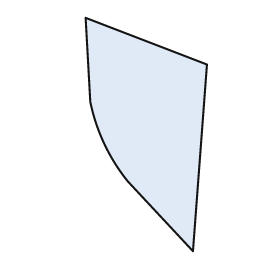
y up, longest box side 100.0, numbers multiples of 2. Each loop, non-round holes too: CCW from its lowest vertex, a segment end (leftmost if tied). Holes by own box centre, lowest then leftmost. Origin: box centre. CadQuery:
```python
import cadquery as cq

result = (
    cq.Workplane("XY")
    .moveTo(20.0, -50.0)
    .lineTo(26.0, 30.0)
    .lineTo(-26.0, 50.0)
    .lineTo(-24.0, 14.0)
    .threePointArc((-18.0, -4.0), (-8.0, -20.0))
    .close()
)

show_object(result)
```